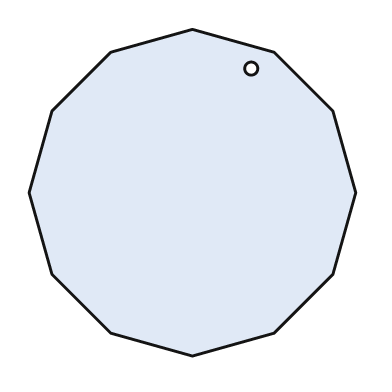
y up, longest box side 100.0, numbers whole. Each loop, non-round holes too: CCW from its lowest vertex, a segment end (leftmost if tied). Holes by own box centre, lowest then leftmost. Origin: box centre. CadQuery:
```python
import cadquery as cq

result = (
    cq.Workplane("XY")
    .moveTo(0.0, -50.0)
    .lineTo(25.0, -43.0)
    .lineTo(43.0, -25.0)
    .lineTo(50.0, 0.0)
    .lineTo(43.0, 25.0)
    .lineTo(25.0, 43.0)
    .lineTo(0.0, 50.0)
    .lineTo(-25.0, 43.0)
    .lineTo(-43.0, 25.0)
    .lineTo(-50.0, 0.0)
    .lineTo(-43.0, -25.0)
    .lineTo(-25.0, -43.0)
    .close()
    .moveTo(18.0, 38.0)
    .circle(2.0)
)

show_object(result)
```